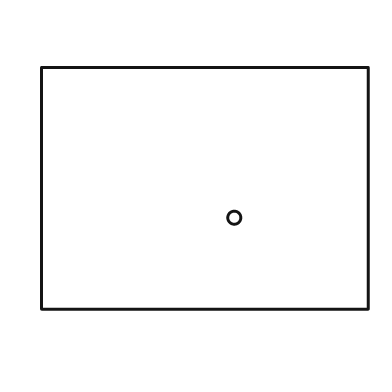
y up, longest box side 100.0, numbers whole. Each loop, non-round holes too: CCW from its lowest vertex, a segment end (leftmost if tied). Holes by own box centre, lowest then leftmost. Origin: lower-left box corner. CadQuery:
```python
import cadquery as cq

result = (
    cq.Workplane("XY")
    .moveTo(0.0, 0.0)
    .lineTo(100.0, 0.0)
    .lineTo(100.0, 74.0)
    .lineTo(0.0, 74.0)
    .close()
    .moveTo(59.0, 28.0)
    .circle(2.0)
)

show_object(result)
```